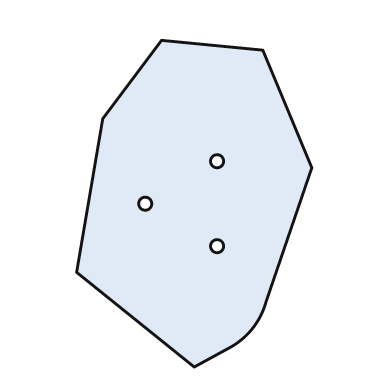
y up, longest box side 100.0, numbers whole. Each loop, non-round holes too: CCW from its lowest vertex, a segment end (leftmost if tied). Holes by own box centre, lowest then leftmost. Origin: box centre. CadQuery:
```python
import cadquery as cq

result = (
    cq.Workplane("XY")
    .moveTo(0.0, -50.0)
    .lineTo(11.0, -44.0)
    .threePointArc((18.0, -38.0), (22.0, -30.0))
    .lineTo(36.0, 11.0)
    .lineTo(21.0, 47.0)
    .lineTo(-10.0, 50.0)
    .lineTo(-28.0, 26.0)
    .lineTo(-36.0, -21.0)
    .close()
    .moveTo(7.0, -13.0)
    .circle(2.0)
    .moveTo(-15.0, 0.0)
    .circle(2.0)
    .moveTo(7.0, 13.0)
    .circle(2.0)
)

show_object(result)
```